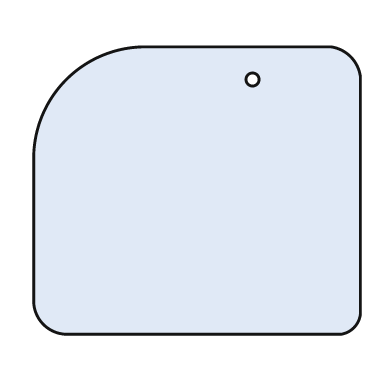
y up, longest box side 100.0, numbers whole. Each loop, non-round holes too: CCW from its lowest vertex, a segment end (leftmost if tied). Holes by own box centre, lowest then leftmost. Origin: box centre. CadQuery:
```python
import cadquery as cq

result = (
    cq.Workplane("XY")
    .moveTo(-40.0, -44.0)
    .lineTo(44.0, -44.0)
    .threePointArc((48.0, -42.0), (50.0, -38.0))
    .lineTo(50.0, 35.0)
    .threePointArc((47.0, 41.0), (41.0, 44.0))
    .lineTo(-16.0, 44.0)
    .threePointArc((-40.0, 34.0), (-50.0, 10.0))
    .lineTo(-50.0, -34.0)
    .threePointArc((-47.0, -41.0), (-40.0, -44.0))
    .close()
    .moveTo(17.0, 34.0)
    .circle(2.0)
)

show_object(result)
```